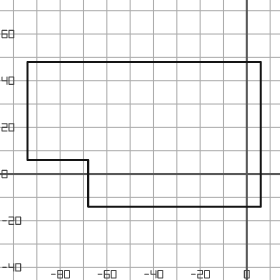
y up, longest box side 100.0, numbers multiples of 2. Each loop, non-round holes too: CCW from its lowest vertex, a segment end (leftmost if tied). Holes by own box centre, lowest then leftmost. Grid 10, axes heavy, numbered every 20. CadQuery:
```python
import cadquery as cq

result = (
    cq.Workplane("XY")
    .moveTo(-68.0, -14.0)
    .lineTo(6.0, -14.0)
    .lineTo(6.0, 48.0)
    .lineTo(-94.0, 48.0)
    .lineTo(-94.0, 6.0)
    .lineTo(-68.0, 6.0)
    .close()
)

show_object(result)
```